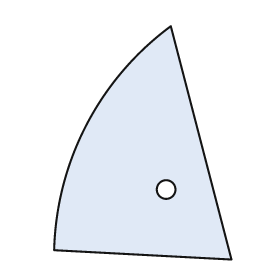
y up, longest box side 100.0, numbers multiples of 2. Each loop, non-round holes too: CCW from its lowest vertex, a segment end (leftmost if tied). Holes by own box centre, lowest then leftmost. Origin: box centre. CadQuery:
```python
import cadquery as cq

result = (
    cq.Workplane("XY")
    .moveTo(38.0, -50.0)
    .lineTo(12.0, 50.0)
    .threePointArc((-24.0, 8.0), (-38.0, -46.0))
    .close()
    .moveTo(10.0, -20.0)
    .circle(4.0)
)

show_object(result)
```